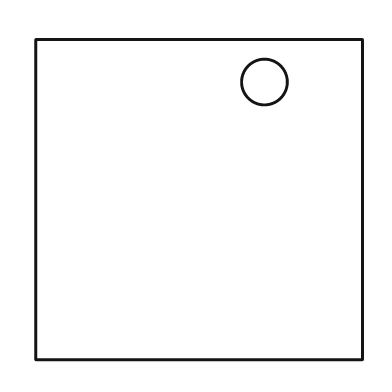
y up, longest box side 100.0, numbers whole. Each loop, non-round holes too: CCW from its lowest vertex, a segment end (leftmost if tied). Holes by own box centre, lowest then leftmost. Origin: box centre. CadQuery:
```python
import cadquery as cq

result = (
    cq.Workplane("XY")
    .moveTo(-50.0, -49.0)
    .lineTo(50.0, -49.0)
    .lineTo(50.0, 49.0)
    .lineTo(-50.0, 49.0)
    .close()
    .moveTo(20.0, 36.0)
    .circle(7.0)
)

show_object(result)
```